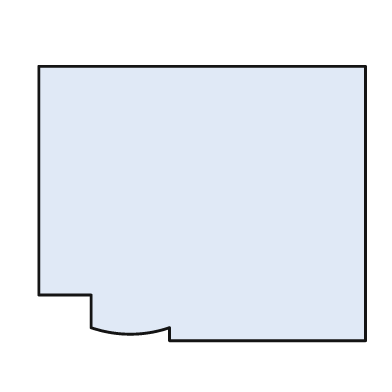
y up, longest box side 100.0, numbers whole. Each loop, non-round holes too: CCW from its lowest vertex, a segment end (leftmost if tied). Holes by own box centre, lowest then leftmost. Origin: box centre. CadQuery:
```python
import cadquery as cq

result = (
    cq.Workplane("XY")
    .moveTo(-10.0, -42.0)
    .lineTo(50.0, -42.0)
    .lineTo(50.0, 42.0)
    .lineTo(-50.0, 42.0)
    .lineTo(-50.0, -28.0)
    .lineTo(-34.0, -28.0)
    .lineTo(-34.0, -38.0)
    .threePointArc((-22.0, -40.0), (-10.0, -38.0))
    .close()
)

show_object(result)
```